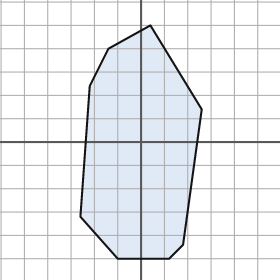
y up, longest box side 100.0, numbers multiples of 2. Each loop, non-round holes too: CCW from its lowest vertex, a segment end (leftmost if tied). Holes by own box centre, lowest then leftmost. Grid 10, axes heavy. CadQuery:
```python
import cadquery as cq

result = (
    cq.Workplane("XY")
    .moveTo(-10.0, -50.0)
    .lineTo(12.0, -50.0)
    .lineTo(18.0, -44.0)
    .lineTo(26.0, 14.0)
    .lineTo(4.0, 50.0)
    .lineTo(-14.0, 40.0)
    .lineTo(-22.0, 24.0)
    .lineTo(-26.0, -32.0)
    .close()
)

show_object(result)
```